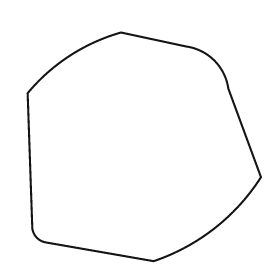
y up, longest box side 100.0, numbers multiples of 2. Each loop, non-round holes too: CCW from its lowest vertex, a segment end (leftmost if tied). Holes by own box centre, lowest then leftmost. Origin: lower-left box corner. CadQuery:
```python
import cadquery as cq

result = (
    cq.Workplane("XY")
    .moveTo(54.0, 0.0)
    .threePointArc((80.0, 14.0), (100.0, 36.0))
    .lineTo(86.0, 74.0)
    .threePointArc((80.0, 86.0), (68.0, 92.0))
    .lineTo(40.0, 98.0)
    .threePointArc((18.0, 88.0), (0.0, 72.0))
    .lineTo(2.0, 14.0)
    .threePointArc((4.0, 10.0), (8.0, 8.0))
    .close()
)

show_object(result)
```